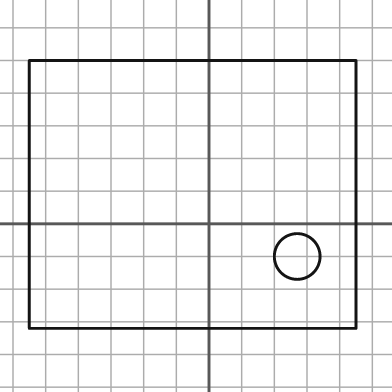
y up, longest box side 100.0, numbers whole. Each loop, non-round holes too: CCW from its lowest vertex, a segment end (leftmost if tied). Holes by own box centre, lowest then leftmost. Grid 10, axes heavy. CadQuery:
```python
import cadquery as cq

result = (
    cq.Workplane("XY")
    .moveTo(-55.0, -32.0)
    .lineTo(45.0, -32.0)
    .lineTo(45.0, 50.0)
    .lineTo(-55.0, 50.0)
    .close()
    .moveTo(27.0, -10.0)
    .circle(7.0)
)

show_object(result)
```